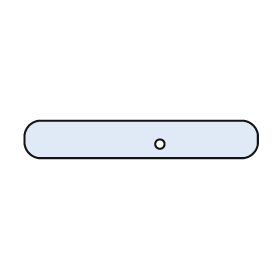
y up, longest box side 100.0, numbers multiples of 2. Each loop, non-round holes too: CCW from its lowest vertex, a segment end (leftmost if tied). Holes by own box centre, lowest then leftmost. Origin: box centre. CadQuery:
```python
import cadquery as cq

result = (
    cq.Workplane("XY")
    .moveTo(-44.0, -8.0)
    .lineTo(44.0, -8.0)
    .threePointArc((48.0, -6.0), (50.0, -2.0))
    .lineTo(50.0, 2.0)
    .threePointArc((48.0, 6.0), (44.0, 8.0))
    .lineTo(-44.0, 8.0)
    .threePointArc((-48.0, 6.0), (-50.0, 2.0))
    .lineTo(-50.0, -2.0)
    .threePointArc((-48.0, -6.0), (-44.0, -8.0))
    .close()
    .moveTo(8.0, -2.0)
    .circle(2.0)
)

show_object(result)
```